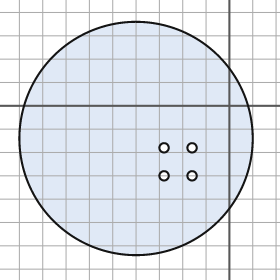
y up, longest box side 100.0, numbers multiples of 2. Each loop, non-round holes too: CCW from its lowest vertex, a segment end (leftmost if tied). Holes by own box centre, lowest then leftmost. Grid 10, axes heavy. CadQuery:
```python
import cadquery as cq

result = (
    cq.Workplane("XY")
    .moveTo(-40.0, -14.0)
    .circle(50.0)
    .moveTo(-28.0, -30.0)
    .circle(2.0)
    .moveTo(-16.0, -30.0)
    .circle(2.0)
    .moveTo(-28.0, -18.0)
    .circle(2.0)
    .moveTo(-16.0, -18.0)
    .circle(2.0)
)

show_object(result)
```